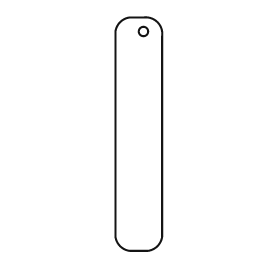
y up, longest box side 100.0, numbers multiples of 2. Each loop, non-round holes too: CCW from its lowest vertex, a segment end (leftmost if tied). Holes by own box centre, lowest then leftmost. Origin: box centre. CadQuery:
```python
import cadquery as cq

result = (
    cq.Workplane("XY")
    .moveTo(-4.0, -50.0)
    .lineTo(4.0, -50.0)
    .threePointArc((8.0, -48.0), (10.0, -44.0))
    .lineTo(10.0, 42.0)
    .threePointArc((8.0, 48.0), (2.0, 50.0))
    .lineTo(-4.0, 50.0)
    .threePointArc((-8.0, 48.0), (-10.0, 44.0))
    .lineTo(-10.0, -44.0)
    .threePointArc((-8.0, -48.0), (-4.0, -50.0))
    .close()
    .moveTo(2.0, 44.0)
    .circle(2.0)
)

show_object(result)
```